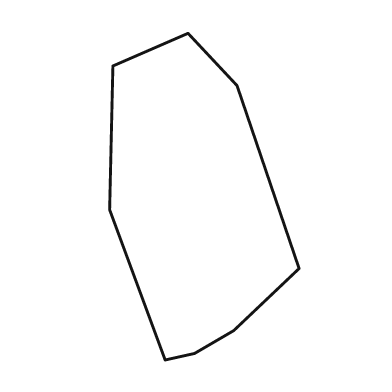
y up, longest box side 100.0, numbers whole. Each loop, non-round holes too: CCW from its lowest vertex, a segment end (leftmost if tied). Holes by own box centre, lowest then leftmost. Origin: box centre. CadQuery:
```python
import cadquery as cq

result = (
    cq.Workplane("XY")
    .moveTo(-12.0, -50.0)
    .lineTo(-3.0, -48.0)
    .lineTo(9.0, -41.0)
    .lineTo(29.0, -22.0)
    .lineTo(10.0, 34.0)
    .lineTo(-5.0, 50.0)
    .lineTo(-28.0, 40.0)
    .lineTo(-29.0, -4.0)
    .close()
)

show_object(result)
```